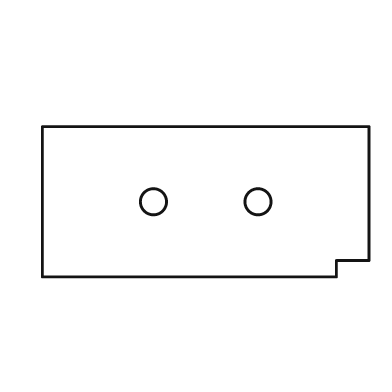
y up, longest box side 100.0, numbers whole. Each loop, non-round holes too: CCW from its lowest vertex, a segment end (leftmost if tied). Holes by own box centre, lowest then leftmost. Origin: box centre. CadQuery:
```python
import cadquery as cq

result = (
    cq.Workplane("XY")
    .moveTo(-50.0, -23.0)
    .lineTo(40.0, -23.0)
    .lineTo(40.0, -18.0)
    .lineTo(50.0, -18.0)
    .lineTo(50.0, 23.0)
    .lineTo(-50.0, 23.0)
    .close()
    .moveTo(-16.0, 0.0)
    .circle(4.0)
    .moveTo(16.0, 0.0)
    .circle(4.0)
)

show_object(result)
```